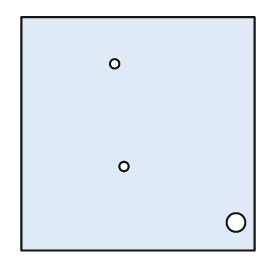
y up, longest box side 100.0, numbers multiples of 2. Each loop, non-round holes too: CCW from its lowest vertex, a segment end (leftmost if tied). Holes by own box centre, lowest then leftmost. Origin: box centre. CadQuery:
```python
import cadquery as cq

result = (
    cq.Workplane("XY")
    .moveTo(-50.0, -50.0)
    .lineTo(50.0, -50.0)
    .lineTo(50.0, 50.0)
    .lineTo(-50.0, 50.0)
    .close()
    .moveTo(42.0, -38.0)
    .circle(4.0)
    .moveTo(-6.0, -14.0)
    .circle(2.0)
    .moveTo(-10.0, 30.0)
    .circle(2.0)
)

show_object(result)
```